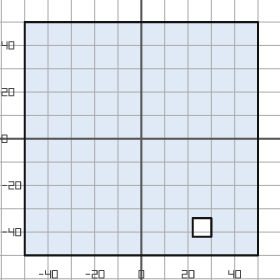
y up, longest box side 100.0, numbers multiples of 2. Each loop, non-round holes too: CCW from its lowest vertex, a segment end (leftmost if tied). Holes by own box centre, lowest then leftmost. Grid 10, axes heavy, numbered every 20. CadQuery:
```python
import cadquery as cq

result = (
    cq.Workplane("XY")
    .moveTo(-50.0, -50.0)
    .lineTo(50.0, -50.0)
    .lineTo(50.0, 50.0)
    .lineTo(-50.0, 50.0)
    .close()
    .moveTo(22.0, -42.0)
    .lineTo(30.0, -42.0)
    .lineTo(30.0, -34.0)
    .lineTo(22.0, -34.0)
    .close()
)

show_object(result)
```